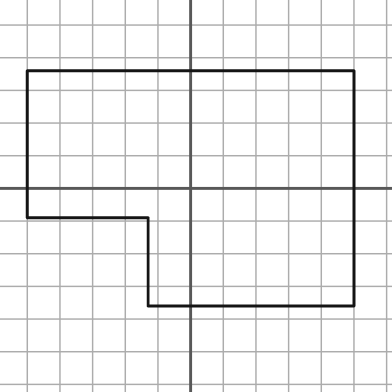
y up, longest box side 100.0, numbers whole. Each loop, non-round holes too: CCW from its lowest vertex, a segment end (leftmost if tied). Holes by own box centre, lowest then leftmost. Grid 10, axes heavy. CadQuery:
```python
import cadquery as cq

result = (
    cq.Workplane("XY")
    .moveTo(-13.0, -36.0)
    .lineTo(50.0, -36.0)
    .lineTo(50.0, 36.0)
    .lineTo(-50.0, 36.0)
    .lineTo(-50.0, -9.0)
    .lineTo(-13.0, -9.0)
    .close()
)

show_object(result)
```